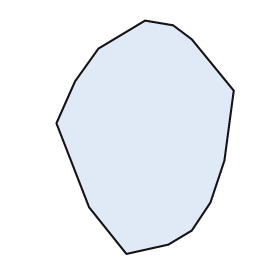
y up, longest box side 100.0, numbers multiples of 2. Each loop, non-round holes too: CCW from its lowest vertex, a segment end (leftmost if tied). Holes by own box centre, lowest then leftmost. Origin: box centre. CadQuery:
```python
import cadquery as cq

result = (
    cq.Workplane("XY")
    .moveTo(-8.0, -50.0)
    .lineTo(10.0, -46.0)
    .lineTo(20.0, -40.0)
    .lineTo(28.0, -28.0)
    .lineTo(34.0, -10.0)
    .lineTo(38.0, 20.0)
    .lineTo(20.0, 42.0)
    .lineTo(12.0, 48.0)
    .lineTo(0.0, 50.0)
    .lineTo(-20.0, 38.0)
    .lineTo(-30.0, 24.0)
    .lineTo(-38.0, 6.0)
    .lineTo(-24.0, -30.0)
    .close()
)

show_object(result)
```